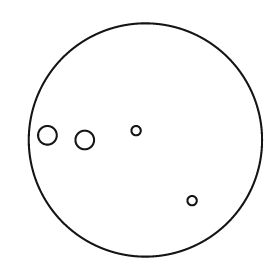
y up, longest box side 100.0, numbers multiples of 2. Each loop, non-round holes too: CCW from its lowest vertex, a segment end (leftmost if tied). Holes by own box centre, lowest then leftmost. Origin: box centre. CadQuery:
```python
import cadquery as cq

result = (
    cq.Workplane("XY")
    .moveTo(0.0, 0.0)
    .circle(50.0)
    .moveTo(20.0, -26.0)
    .circle(2.0)
    .moveTo(-26.0, 0.0)
    .circle(4.0)
    .moveTo(-42.0, 2.0)
    .circle(4.0)
    .moveTo(-4.0, 4.0)
    .circle(2.0)
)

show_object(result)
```